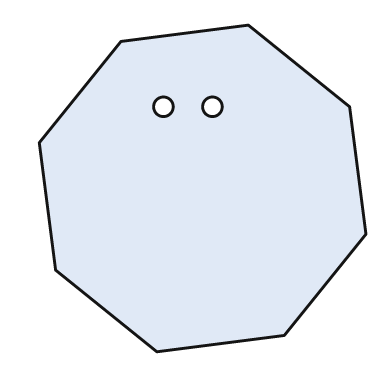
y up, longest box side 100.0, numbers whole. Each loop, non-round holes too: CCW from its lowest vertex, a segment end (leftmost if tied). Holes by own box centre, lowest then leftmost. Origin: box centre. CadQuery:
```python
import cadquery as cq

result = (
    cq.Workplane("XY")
    .moveTo(-14.0, -50.0)
    .lineTo(25.0, -45.0)
    .lineTo(50.0, -14.0)
    .lineTo(45.0, 25.0)
    .lineTo(14.0, 50.0)
    .lineTo(-25.0, 45.0)
    .lineTo(-50.0, 14.0)
    .lineTo(-45.0, -25.0)
    .close()
    .moveTo(-12.0, 25.0)
    .circle(3.0)
    .moveTo(3.0, 25.0)
    .circle(3.0)
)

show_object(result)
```